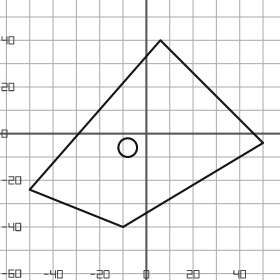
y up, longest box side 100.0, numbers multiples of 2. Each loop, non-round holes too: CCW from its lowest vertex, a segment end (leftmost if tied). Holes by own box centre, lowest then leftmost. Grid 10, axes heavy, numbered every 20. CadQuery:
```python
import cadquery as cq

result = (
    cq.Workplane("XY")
    .moveTo(-10.0, -40.0)
    .lineTo(50.0, -4.0)
    .lineTo(6.0, 40.0)
    .lineTo(-50.0, -24.0)
    .close()
    .moveTo(-8.0, -6.0)
    .circle(4.0)
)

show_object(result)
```